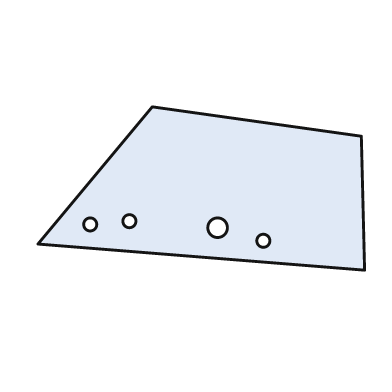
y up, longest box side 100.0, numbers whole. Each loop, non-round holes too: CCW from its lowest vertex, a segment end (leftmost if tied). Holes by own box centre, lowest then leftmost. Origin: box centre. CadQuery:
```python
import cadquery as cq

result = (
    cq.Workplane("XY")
    .moveTo(50.0, -25.0)
    .lineTo(49.0, 16.0)
    .lineTo(-15.0, 25.0)
    .lineTo(-50.0, -17.0)
    .close()
    .moveTo(19.0, -16.0)
    .circle(2.0)
    .moveTo(5.0, -12.0)
    .circle(3.0)
    .moveTo(-34.0, -11.0)
    .circle(2.0)
    .moveTo(-22.0, -10.0)
    .circle(2.0)
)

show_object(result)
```